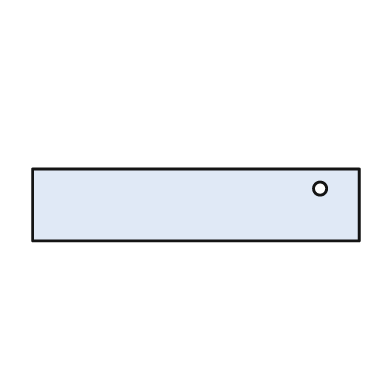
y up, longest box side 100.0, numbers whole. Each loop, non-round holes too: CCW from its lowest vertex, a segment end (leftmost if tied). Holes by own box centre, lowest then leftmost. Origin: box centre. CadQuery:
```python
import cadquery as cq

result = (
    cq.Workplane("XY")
    .moveTo(-50.0, -11.0)
    .lineTo(50.0, -11.0)
    .lineTo(50.0, 11.0)
    .lineTo(-50.0, 11.0)
    .close()
    .moveTo(38.0, 5.0)
    .circle(2.0)
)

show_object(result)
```